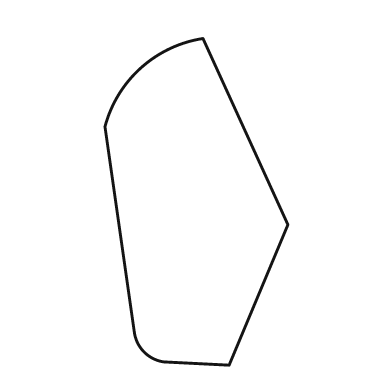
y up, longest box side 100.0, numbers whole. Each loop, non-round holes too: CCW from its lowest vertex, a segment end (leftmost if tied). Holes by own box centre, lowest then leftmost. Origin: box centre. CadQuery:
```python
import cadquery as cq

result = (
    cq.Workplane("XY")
    .moveTo(10.0, -50.0)
    .lineTo(28.0, -7.0)
    .lineTo(2.0, 50.0)
    .threePointArc((-17.0, 41.0), (-28.0, 23.0))
    .lineTo(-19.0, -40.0)
    .threePointArc((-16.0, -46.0), (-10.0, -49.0))
    .close()
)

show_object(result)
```